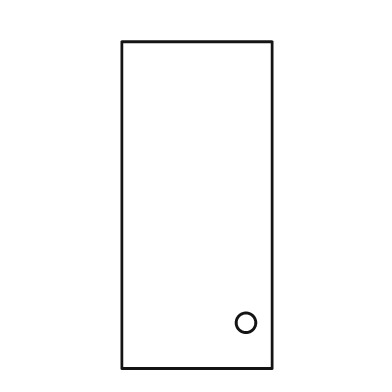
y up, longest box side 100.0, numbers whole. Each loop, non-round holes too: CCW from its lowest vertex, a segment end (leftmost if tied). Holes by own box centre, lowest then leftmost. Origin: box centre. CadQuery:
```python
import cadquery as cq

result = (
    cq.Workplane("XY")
    .moveTo(-23.0, -50.0)
    .lineTo(23.0, -50.0)
    .lineTo(23.0, 50.0)
    .lineTo(-23.0, 50.0)
    .close()
    .moveTo(15.0, -36.0)
    .circle(3.0)
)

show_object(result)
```